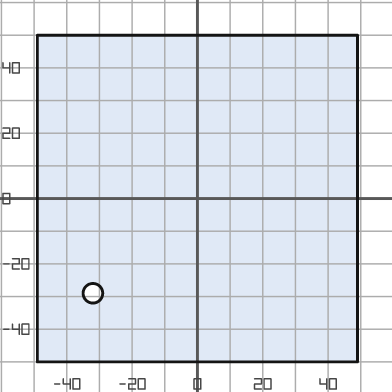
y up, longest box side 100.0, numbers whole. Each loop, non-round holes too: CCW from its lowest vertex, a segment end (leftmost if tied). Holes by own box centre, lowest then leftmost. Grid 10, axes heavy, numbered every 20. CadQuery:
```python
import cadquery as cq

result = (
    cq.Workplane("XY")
    .moveTo(-49.0, -50.0)
    .lineTo(49.0, -50.0)
    .lineTo(49.0, 50.0)
    .lineTo(-49.0, 50.0)
    .close()
    .moveTo(-32.0, -29.0)
    .circle(3.0)
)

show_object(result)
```